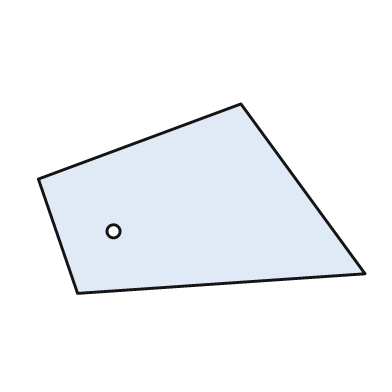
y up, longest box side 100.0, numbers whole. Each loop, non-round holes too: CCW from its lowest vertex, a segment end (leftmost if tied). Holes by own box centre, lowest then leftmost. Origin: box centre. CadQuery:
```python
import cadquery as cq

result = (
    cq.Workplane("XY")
    .moveTo(-38.0, -29.0)
    .lineTo(50.0, -23.0)
    .lineTo(12.0, 29.0)
    .lineTo(-50.0, 6.0)
    .close()
    .moveTo(-27.0, -10.0)
    .circle(2.0)
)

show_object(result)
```